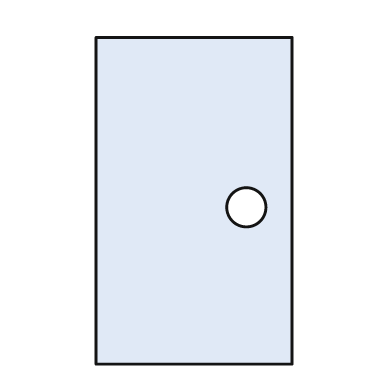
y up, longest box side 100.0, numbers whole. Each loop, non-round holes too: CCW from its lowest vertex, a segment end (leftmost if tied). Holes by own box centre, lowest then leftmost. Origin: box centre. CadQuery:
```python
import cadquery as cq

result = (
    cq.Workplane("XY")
    .moveTo(-30.0, -50.0)
    .lineTo(30.0, -50.0)
    .lineTo(30.0, 50.0)
    .lineTo(-30.0, 50.0)
    .close()
    .moveTo(16.0, -2.0)
    .circle(6.0)
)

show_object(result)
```